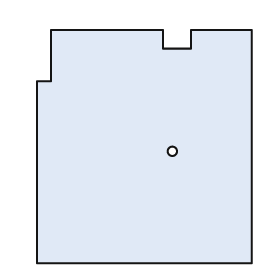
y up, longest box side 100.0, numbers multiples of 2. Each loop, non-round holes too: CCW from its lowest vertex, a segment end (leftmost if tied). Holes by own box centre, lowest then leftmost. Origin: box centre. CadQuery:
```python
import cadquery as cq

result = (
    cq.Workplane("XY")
    .moveTo(-46.0, -50.0)
    .lineTo(46.0, -50.0)
    .lineTo(46.0, 50.0)
    .lineTo(20.0, 50.0)
    .lineTo(20.0, 42.0)
    .lineTo(8.0, 42.0)
    .lineTo(8.0, 50.0)
    .lineTo(-40.0, 50.0)
    .lineTo(-40.0, 28.0)
    .lineTo(-46.0, 28.0)
    .close()
    .moveTo(12.0, -2.0)
    .circle(2.0)
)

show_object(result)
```